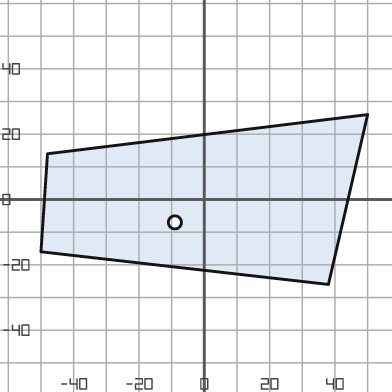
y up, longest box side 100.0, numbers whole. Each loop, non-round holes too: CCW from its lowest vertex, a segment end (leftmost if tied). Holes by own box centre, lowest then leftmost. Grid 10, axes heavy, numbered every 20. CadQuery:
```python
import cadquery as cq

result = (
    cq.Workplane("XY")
    .moveTo(38.0, -26.0)
    .lineTo(50.0, 26.0)
    .lineTo(-48.0, 14.0)
    .lineTo(-50.0, -16.0)
    .close()
    .moveTo(-9.0, -7.0)
    .circle(2.0)
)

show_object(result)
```